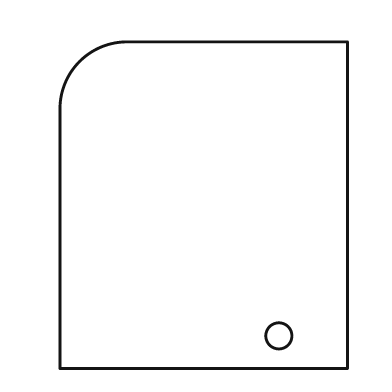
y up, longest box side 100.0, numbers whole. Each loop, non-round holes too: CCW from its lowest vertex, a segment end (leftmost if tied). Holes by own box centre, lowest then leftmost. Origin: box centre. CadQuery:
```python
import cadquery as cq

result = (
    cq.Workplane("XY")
    .moveTo(-44.0, -50.0)
    .lineTo(44.0, -50.0)
    .lineTo(44.0, 50.0)
    .lineTo(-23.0, 50.0)
    .threePointArc((-38.0, 44.0), (-44.0, 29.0))
    .close()
    .moveTo(23.0, -40.0)
    .circle(4.0)
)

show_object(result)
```